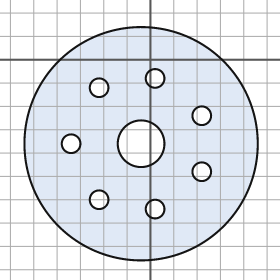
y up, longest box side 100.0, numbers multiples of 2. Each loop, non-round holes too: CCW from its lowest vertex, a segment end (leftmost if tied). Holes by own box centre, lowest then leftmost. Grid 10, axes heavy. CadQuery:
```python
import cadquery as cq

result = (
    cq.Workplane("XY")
    .moveTo(-4.0, -36.0)
    .circle(50.0)
    .moveTo(2.0, -64.0)
    .circle(4.0)
    .moveTo(-22.0, -60.0)
    .circle(4.0)
    .moveTo(22.0, -48.0)
    .circle(4.0)
    .moveTo(-34.0, -36.0)
    .circle(4.0)
    .moveTo(-4.0, -36.0)
    .circle(10.0)
    .moveTo(22.0, -24.0)
    .circle(4.0)
    .moveTo(-22.0, -12.0)
    .circle(4.0)
    .moveTo(2.0, -8.0)
    .circle(4.0)
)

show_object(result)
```